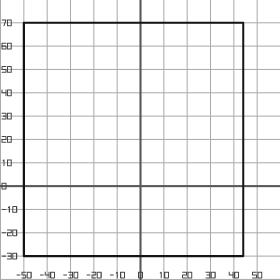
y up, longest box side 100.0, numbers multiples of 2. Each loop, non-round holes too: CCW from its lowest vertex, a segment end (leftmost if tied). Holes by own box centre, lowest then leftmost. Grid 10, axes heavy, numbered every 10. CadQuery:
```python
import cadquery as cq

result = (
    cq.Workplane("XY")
    .moveTo(-50.0, -30.0)
    .lineTo(44.0, -30.0)
    .lineTo(44.0, 70.0)
    .lineTo(-50.0, 70.0)
    .close()
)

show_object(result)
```